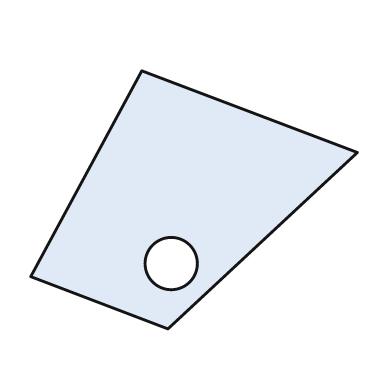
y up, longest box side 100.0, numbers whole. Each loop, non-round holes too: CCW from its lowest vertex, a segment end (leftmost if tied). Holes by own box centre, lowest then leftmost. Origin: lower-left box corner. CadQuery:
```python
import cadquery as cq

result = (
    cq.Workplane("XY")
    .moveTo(42.0, 0.0)
    .lineTo(100.0, 54.0)
    .lineTo(34.0, 79.0)
    .lineTo(0.0, 16.0)
    .close()
    .moveTo(43.0, 20.0)
    .circle(8.0)
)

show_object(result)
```